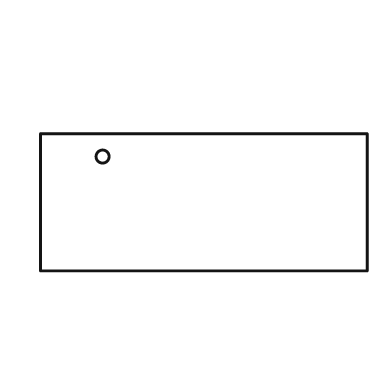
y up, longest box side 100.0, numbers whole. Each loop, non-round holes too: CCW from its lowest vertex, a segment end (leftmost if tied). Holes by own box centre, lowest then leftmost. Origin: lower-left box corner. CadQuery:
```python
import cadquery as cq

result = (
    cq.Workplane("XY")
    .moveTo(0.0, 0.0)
    .lineTo(100.0, 0.0)
    .lineTo(100.0, 42.0)
    .lineTo(0.0, 42.0)
    .close()
    .moveTo(19.0, 35.0)
    .circle(2.0)
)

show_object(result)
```